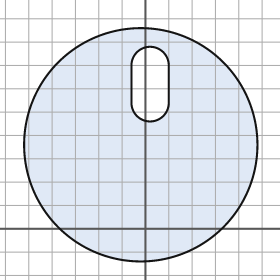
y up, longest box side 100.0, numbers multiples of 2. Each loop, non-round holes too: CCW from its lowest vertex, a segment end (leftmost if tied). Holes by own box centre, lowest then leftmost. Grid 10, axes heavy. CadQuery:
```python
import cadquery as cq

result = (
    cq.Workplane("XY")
    .moveTo(-2.0, 36.0)
    .circle(50.0)
    .moveTo(-6.0, 54.0)
    .threePointArc((2.0, 46.0), (10.0, 54.0))
    .lineTo(10.0, 70.0)
    .threePointArc((2.0, 78.0), (-6.0, 70.0))
    .close()
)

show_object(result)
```